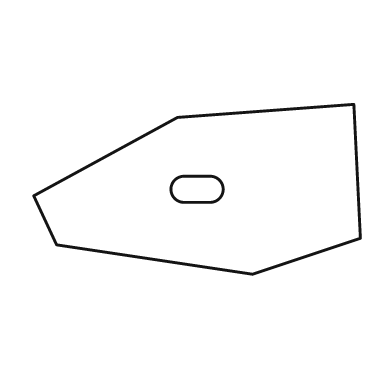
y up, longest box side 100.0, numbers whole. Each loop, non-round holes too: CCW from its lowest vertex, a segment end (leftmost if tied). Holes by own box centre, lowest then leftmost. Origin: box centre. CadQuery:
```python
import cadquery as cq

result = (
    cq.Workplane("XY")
    .moveTo(17.0, -26.0)
    .lineTo(50.0, -15.0)
    .lineTo(48.0, 26.0)
    .lineTo(-6.0, 22.0)
    .lineTo(-50.0, -2.0)
    .lineTo(-43.0, -17.0)
    .close()
    .moveTo(-4.0, -4.0)
    .lineTo(4.0, -4.0)
    .threePointArc((8.0, 0.0), (4.0, 4.0))
    .lineTo(-4.0, 4.0)
    .threePointArc((-8.0, 0.0), (-4.0, -4.0))
    .close()
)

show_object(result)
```